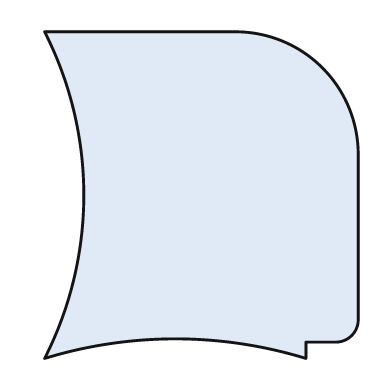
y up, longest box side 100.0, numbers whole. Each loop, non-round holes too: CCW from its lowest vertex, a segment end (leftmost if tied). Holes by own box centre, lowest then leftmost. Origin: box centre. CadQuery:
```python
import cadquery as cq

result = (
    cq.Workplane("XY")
    .moveTo(-48.0, -50.0)
    .threePointArc((-8.0, -44.0), (32.0, -50.0))
    .lineTo(32.0, -45.0)
    .lineTo(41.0, -45.0)
    .threePointArc((46.0, -43.0), (48.0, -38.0))
    .lineTo(48.0, 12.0)
    .threePointArc((37.0, 39.0), (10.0, 50.0))
    .lineTo(-48.0, 50.0)
    .threePointArc((-36.0, 0.0), (-48.0, -50.0))
    .close()
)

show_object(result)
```